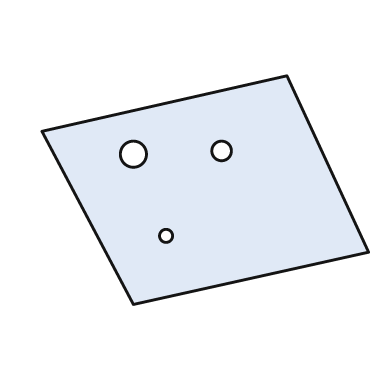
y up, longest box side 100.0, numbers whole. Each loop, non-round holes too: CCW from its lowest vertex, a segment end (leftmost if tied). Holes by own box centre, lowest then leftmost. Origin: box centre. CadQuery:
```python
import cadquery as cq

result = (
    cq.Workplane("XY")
    .moveTo(-22.0, -35.0)
    .lineTo(50.0, -19.0)
    .lineTo(25.0, 35.0)
    .lineTo(-50.0, 18.0)
    .close()
    .moveTo(-12.0, -14.0)
    .circle(2.0)
    .moveTo(-22.0, 11.0)
    .circle(4.0)
    .moveTo(5.0, 12.0)
    .circle(3.0)
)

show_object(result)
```